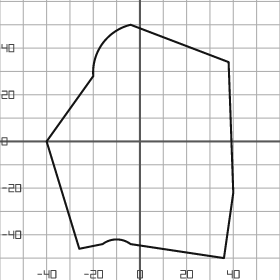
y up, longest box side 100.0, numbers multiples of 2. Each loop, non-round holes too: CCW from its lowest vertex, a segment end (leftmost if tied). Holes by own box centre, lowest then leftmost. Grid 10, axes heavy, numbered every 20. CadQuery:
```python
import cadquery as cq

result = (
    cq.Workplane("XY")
    .moveTo(36.0, -50.0)
    .lineTo(40.0, -22.0)
    .lineTo(38.0, 34.0)
    .lineTo(-4.0, 50.0)
    .threePointArc((-16.0, 42.0), (-20.0, 28.0))
    .lineTo(-40.0, 0.0)
    .lineTo(-26.0, -46.0)
    .lineTo(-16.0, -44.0)
    .threePointArc((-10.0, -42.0), (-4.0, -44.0))
    .close()
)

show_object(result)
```